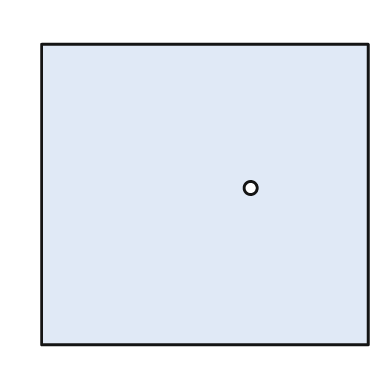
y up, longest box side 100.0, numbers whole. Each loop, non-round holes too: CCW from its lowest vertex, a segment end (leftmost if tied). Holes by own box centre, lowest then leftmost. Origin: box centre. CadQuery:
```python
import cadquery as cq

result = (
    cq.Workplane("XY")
    .moveTo(-50.0, -46.0)
    .lineTo(50.0, -46.0)
    .lineTo(50.0, 46.0)
    .lineTo(-50.0, 46.0)
    .close()
    .moveTo(14.0, 2.0)
    .circle(2.0)
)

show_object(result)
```